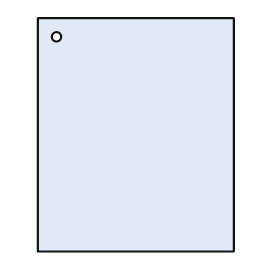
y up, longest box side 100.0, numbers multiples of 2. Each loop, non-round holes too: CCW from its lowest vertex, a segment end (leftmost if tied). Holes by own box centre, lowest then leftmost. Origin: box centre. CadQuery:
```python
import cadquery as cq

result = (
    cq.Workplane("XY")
    .moveTo(-42.0, -50.0)
    .lineTo(42.0, -50.0)
    .lineTo(42.0, 50.0)
    .lineTo(-42.0, 50.0)
    .close()
    .moveTo(-34.0, 42.0)
    .circle(2.0)
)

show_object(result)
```